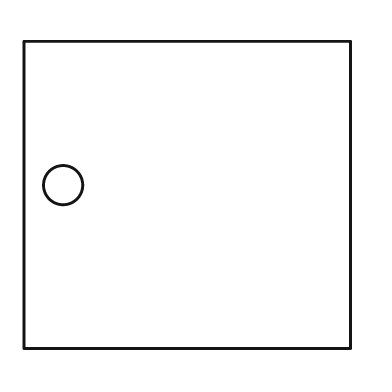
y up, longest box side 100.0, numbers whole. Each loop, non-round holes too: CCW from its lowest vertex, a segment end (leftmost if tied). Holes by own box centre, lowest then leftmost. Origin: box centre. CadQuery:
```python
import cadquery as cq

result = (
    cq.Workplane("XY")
    .moveTo(-50.0, -47.0)
    .lineTo(50.0, -47.0)
    .lineTo(50.0, 47.0)
    .lineTo(-50.0, 47.0)
    .close()
    .moveTo(-38.0, 3.0)
    .circle(6.0)
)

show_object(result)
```